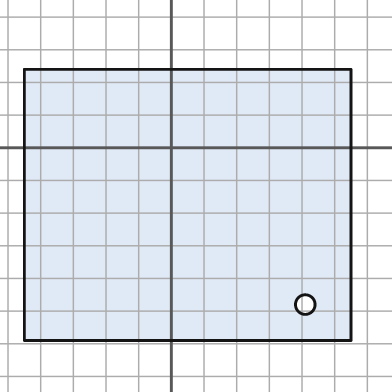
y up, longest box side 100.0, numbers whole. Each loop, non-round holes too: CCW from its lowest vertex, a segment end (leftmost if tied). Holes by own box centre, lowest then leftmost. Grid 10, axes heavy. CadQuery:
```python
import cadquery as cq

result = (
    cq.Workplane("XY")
    .moveTo(-45.0, -59.0)
    .lineTo(55.0, -59.0)
    .lineTo(55.0, 24.0)
    .lineTo(-45.0, 24.0)
    .close()
    .moveTo(41.0, -48.0)
    .circle(3.0)
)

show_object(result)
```